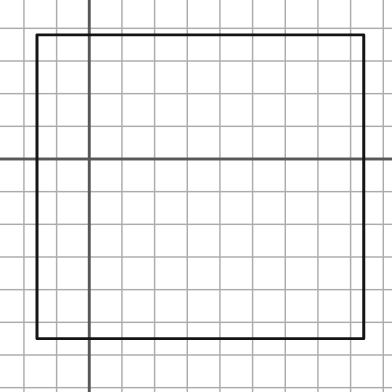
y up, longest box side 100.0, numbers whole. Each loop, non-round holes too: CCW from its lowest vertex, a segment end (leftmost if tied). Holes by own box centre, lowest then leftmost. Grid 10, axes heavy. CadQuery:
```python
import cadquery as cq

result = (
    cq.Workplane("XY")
    .moveTo(-16.0, -55.0)
    .lineTo(84.0, -55.0)
    .lineTo(84.0, 38.0)
    .lineTo(-16.0, 38.0)
    .close()
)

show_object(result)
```